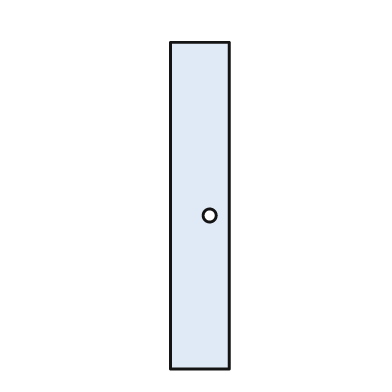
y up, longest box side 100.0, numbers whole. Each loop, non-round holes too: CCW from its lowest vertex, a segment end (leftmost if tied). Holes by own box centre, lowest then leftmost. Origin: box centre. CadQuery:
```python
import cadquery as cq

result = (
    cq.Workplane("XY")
    .moveTo(-9.0, -50.0)
    .lineTo(9.0, -50.0)
    .lineTo(9.0, 50.0)
    .lineTo(-9.0, 50.0)
    .close()
    .moveTo(3.0, -3.0)
    .circle(2.0)
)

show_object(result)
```